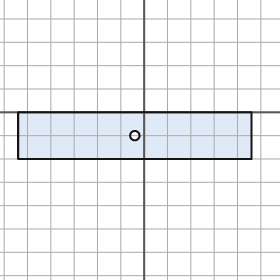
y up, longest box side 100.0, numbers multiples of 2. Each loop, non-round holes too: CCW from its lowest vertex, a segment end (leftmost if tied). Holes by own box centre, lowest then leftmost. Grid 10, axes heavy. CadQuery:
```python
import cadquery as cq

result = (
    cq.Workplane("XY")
    .moveTo(-54.0, -20.0)
    .lineTo(46.0, -20.0)
    .lineTo(46.0, 0.0)
    .lineTo(-54.0, 0.0)
    .close()
    .moveTo(-4.0, -10.0)
    .circle(2.0)
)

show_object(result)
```